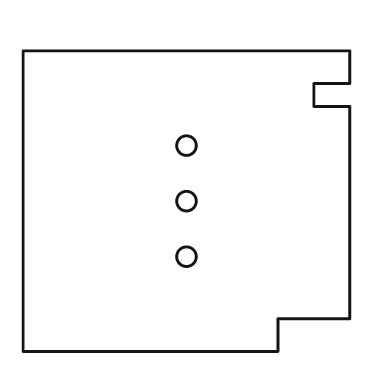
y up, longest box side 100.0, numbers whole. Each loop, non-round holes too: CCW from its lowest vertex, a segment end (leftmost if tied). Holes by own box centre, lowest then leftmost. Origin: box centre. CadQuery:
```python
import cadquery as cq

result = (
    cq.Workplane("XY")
    .moveTo(-50.0, -46.0)
    .lineTo(28.0, -46.0)
    .lineTo(28.0, -36.0)
    .lineTo(50.0, -36.0)
    .lineTo(50.0, 29.0)
    .lineTo(39.0, 29.0)
    .lineTo(39.0, 36.0)
    .lineTo(50.0, 36.0)
    .lineTo(50.0, 46.0)
    .lineTo(-50.0, 46.0)
    .close()
    .moveTo(0.0, -17.0)
    .circle(3.0)
    .moveTo(0.0, 0.0)
    .circle(3.0)
    .moveTo(0.0, 17.0)
    .circle(3.0)
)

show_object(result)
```